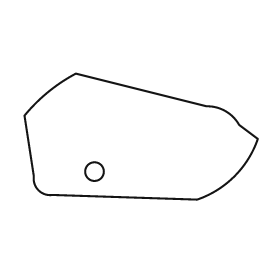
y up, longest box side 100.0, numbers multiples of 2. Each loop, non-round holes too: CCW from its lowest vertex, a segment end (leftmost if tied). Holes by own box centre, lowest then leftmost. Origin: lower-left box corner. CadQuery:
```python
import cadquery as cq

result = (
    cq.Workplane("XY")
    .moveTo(74.0, 0.0)
    .threePointArc((90.0, 10.0), (100.0, 26.0))
    .lineTo(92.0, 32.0)
    .threePointArc((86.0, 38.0), (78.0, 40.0))
    .lineTo(22.0, 54.0)
    .threePointArc((10.0, 46.0), (0.0, 36.0))
    .lineTo(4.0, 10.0)
    .threePointArc((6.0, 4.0), (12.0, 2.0))
    .close()
    .moveTo(30.0, 12.0)
    .circle(4.0)
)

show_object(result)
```